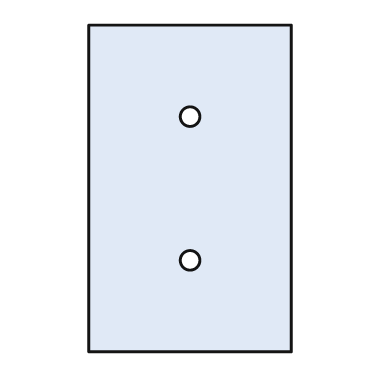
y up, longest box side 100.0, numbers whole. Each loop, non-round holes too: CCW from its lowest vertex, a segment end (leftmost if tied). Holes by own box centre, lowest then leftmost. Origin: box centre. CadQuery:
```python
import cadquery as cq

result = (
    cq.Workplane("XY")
    .moveTo(-31.0, -50.0)
    .lineTo(31.0, -50.0)
    .lineTo(31.0, 50.0)
    .lineTo(-31.0, 50.0)
    .close()
    .moveTo(0.0, -22.0)
    .circle(3.0)
    .moveTo(0.0, 22.0)
    .circle(3.0)
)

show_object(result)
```